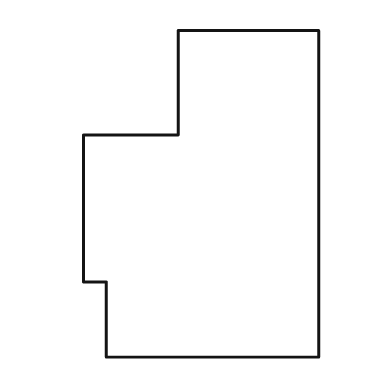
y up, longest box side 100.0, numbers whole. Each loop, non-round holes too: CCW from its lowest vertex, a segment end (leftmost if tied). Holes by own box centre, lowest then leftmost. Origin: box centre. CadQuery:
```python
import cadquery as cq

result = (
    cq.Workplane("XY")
    .moveTo(-29.0, -50.0)
    .lineTo(36.0, -50.0)
    .lineTo(36.0, 50.0)
    .lineTo(-7.0, 50.0)
    .lineTo(-7.0, 18.0)
    .lineTo(-36.0, 18.0)
    .lineTo(-36.0, -27.0)
    .lineTo(-29.0, -27.0)
    .close()
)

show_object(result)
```